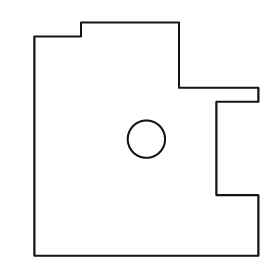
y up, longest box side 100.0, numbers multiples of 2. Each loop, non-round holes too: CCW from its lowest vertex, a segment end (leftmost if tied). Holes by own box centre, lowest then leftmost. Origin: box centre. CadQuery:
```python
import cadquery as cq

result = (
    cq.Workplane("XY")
    .moveTo(-48.0, -50.0)
    .lineTo(48.0, -50.0)
    .lineTo(48.0, -24.0)
    .lineTo(30.0, -24.0)
    .lineTo(30.0, 16.0)
    .lineTo(48.0, 16.0)
    .lineTo(48.0, 22.0)
    .lineTo(14.0, 22.0)
    .lineTo(14.0, 50.0)
    .lineTo(-28.0, 50.0)
    .lineTo(-28.0, 44.0)
    .lineTo(-48.0, 44.0)
    .close()
    .moveTo(0.0, 0.0)
    .circle(8.0)
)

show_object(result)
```